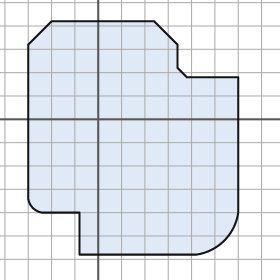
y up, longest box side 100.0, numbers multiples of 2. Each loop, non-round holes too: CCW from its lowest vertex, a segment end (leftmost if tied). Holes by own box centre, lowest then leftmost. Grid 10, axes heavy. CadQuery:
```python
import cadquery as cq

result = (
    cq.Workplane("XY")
    .moveTo(-8.0, -58.0)
    .lineTo(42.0, -58.0)
    .threePointArc((54.0, -52.0), (60.0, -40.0))
    .lineTo(60.0, 18.0)
    .lineTo(38.0, 18.0)
    .lineTo(34.0, 22.0)
    .lineTo(34.0, 32.0)
    .lineTo(24.0, 42.0)
    .lineTo(-20.0, 42.0)
    .lineTo(-30.0, 32.0)
    .lineTo(-30.0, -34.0)
    .threePointArc((-28.0, -38.0), (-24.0, -40.0))
    .lineTo(-8.0, -40.0)
    .close()
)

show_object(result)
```